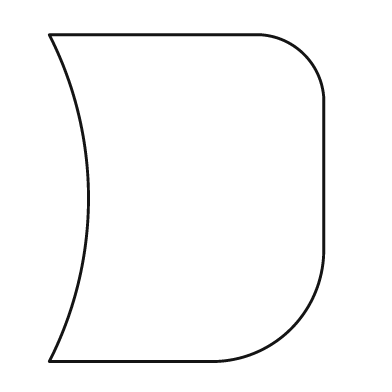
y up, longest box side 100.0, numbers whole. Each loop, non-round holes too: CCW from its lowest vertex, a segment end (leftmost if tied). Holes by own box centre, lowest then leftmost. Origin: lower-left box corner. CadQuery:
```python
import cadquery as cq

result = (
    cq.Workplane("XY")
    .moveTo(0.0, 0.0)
    .lineTo(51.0, 0.0)
    .threePointArc((74.0, 10.0), (84.0, 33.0))
    .lineTo(84.0, 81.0)
    .threePointArc((78.0, 94.0), (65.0, 100.0))
    .lineTo(0.0, 100.0)
    .threePointArc((12.0, 50.0), (0.0, 0.0))
    .close()
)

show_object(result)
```